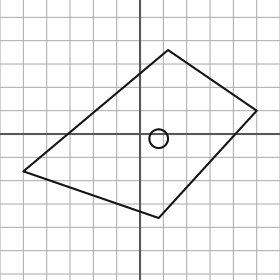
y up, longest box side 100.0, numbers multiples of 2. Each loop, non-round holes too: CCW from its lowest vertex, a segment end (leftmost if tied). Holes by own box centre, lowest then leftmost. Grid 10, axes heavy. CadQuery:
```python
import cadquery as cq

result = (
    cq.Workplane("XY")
    .moveTo(8.0, -36.0)
    .lineTo(50.0, 10.0)
    .lineTo(12.0, 36.0)
    .lineTo(-50.0, -16.0)
    .close()
    .moveTo(8.0, -2.0)
    .circle(4.0)
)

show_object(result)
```